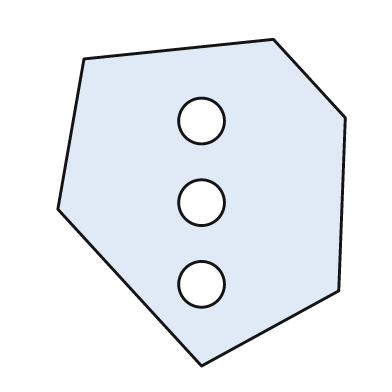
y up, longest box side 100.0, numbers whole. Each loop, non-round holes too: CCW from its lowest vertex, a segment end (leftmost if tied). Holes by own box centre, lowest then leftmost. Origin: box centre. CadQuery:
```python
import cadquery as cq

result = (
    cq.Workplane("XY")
    .moveTo(0.0, -50.0)
    .lineTo(42.0, -27.0)
    .lineTo(44.0, 26.0)
    .lineTo(22.0, 50.0)
    .lineTo(-36.0, 44.0)
    .lineTo(-44.0, -2.0)
    .close()
    .moveTo(0.0, -25.0)
    .circle(7.0)
    .moveTo(0.0, 0.0)
    .circle(7.0)
    .moveTo(0.0, 25.0)
    .circle(7.0)
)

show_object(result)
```